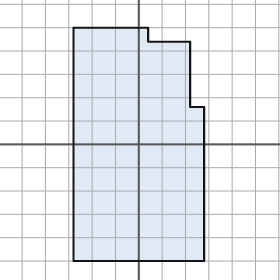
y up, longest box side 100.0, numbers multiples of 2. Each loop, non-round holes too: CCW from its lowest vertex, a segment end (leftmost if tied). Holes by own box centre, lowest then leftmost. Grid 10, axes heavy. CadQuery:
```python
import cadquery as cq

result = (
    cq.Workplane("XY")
    .moveTo(-28.0, -50.0)
    .lineTo(28.0, -50.0)
    .lineTo(28.0, 16.0)
    .lineTo(22.0, 16.0)
    .lineTo(22.0, 44.0)
    .lineTo(4.0, 44.0)
    .lineTo(4.0, 50.0)
    .lineTo(-28.0, 50.0)
    .close()
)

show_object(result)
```